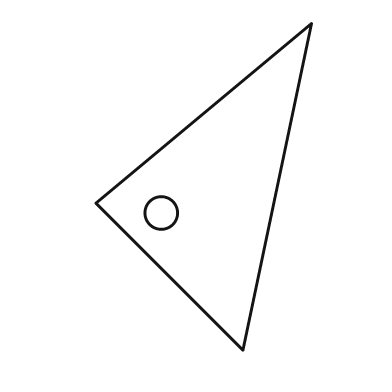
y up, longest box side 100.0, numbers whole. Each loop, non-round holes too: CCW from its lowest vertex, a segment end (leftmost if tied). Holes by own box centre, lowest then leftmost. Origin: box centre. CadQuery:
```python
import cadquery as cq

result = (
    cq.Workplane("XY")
    .moveTo(12.0, -50.0)
    .lineTo(33.0, 50.0)
    .lineTo(-33.0, -5.0)
    .close()
    .moveTo(-13.0, -8.0)
    .circle(5.0)
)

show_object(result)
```